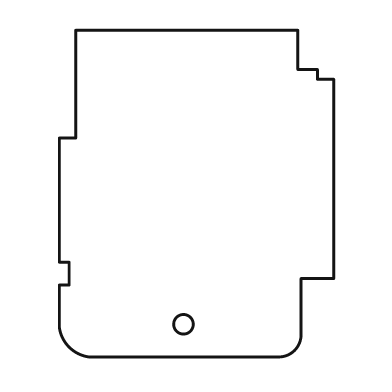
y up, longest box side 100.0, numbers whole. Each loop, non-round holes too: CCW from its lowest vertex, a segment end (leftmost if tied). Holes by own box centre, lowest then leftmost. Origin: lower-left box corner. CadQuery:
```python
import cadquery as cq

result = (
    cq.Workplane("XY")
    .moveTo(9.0, 0.0)
    .lineTo(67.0, 0.0)
    .threePointArc((72.0, 2.0), (74.0, 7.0))
    .lineTo(74.0, 24.0)
    .lineTo(84.0, 24.0)
    .lineTo(84.0, 85.0)
    .lineTo(79.0, 85.0)
    .lineTo(79.0, 88.0)
    .lineTo(73.0, 88.0)
    .lineTo(73.0, 100.0)
    .lineTo(5.0, 100.0)
    .lineTo(5.0, 67.0)
    .lineTo(0.0, 67.0)
    .lineTo(0.0, 29.0)
    .lineTo(3.0, 29.0)
    .lineTo(3.0, 22.0)
    .lineTo(0.0, 22.0)
    .lineTo(0.0, 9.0)
    .threePointArc((3.0, 3.0), (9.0, 0.0))
    .close()
    .moveTo(38.0, 10.0)
    .circle(3.0)
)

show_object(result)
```